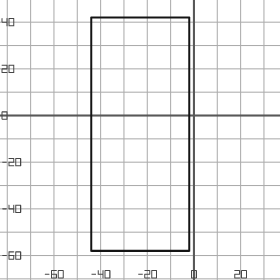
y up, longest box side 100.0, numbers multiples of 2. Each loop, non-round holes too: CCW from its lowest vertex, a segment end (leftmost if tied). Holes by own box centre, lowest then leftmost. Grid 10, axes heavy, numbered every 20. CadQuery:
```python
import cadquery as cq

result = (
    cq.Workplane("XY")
    .moveTo(-44.0, -58.0)
    .lineTo(-2.0, -58.0)
    .lineTo(-2.0, 42.0)
    .lineTo(-44.0, 42.0)
    .close()
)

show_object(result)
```